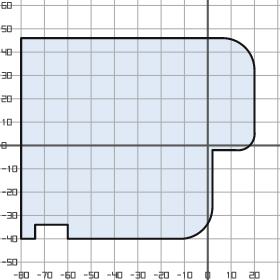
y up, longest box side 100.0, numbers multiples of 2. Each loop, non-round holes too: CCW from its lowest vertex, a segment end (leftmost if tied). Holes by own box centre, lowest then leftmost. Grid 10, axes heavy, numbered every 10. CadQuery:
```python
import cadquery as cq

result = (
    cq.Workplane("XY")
    .moveTo(-80.0, -40.0)
    .lineTo(-74.0, -40.0)
    .lineTo(-74.0, -34.0)
    .lineTo(-60.0, -34.0)
    .lineTo(-60.0, -40.0)
    .lineTo(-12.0, -40.0)
    .threePointArc((-2.0, -36.0), (2.0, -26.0))
    .lineTo(2.0, -2.0)
    .lineTo(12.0, -2.0)
    .threePointArc((18.0, 0.0), (20.0, 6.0))
    .lineTo(20.0, 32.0)
    .threePointArc((16.0, 42.0), (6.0, 46.0))
    .lineTo(-80.0, 46.0)
    .close()
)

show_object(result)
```